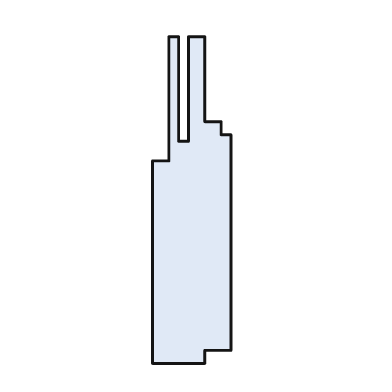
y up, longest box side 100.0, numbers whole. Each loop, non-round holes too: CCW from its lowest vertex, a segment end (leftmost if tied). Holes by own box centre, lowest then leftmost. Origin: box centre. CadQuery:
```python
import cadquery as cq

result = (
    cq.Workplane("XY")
    .moveTo(-12.0, -50.0)
    .lineTo(4.0, -50.0)
    .lineTo(4.0, -46.0)
    .lineTo(12.0, -46.0)
    .lineTo(12.0, 20.0)
    .lineTo(9.0, 20.0)
    .lineTo(9.0, 24.0)
    .lineTo(4.0, 24.0)
    .lineTo(4.0, 50.0)
    .lineTo(-1.0, 50.0)
    .lineTo(-1.0, 18.0)
    .lineTo(-4.0, 18.0)
    .lineTo(-4.0, 50.0)
    .lineTo(-7.0, 50.0)
    .lineTo(-7.0, 12.0)
    .lineTo(-12.0, 12.0)
    .close()
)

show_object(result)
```